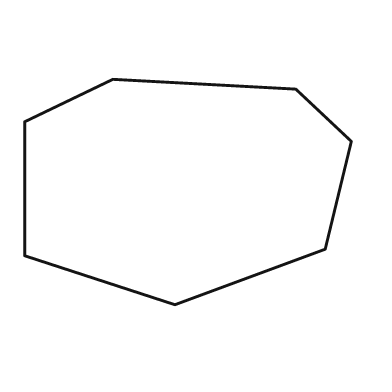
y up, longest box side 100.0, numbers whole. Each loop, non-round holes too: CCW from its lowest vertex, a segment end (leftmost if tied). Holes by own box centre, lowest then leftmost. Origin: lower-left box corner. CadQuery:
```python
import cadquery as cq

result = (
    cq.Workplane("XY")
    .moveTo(46.0, 0.0)
    .lineTo(92.0, 17.0)
    .lineTo(100.0, 50.0)
    .lineTo(83.0, 66.0)
    .lineTo(27.0, 69.0)
    .lineTo(0.0, 56.0)
    .lineTo(0.0, 15.0)
    .close()
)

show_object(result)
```